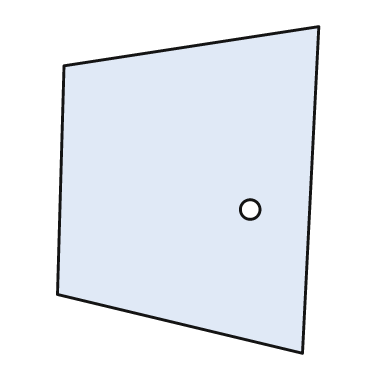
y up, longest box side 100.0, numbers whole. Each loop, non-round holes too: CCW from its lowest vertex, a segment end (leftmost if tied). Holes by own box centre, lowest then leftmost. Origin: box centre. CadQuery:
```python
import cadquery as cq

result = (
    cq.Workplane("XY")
    .moveTo(35.0, -50.0)
    .lineTo(40.0, 50.0)
    .lineTo(-38.0, 38.0)
    .lineTo(-40.0, -32.0)
    .close()
    .moveTo(19.0, -6.0)
    .circle(3.0)
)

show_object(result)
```